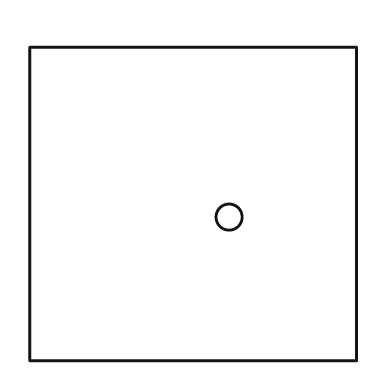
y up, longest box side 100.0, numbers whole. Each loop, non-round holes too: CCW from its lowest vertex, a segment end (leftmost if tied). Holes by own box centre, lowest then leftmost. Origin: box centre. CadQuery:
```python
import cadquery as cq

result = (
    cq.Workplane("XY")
    .moveTo(-50.0, -48.0)
    .lineTo(50.0, -48.0)
    .lineTo(50.0, 48.0)
    .lineTo(-50.0, 48.0)
    .close()
    .moveTo(11.0, -4.0)
    .circle(4.0)
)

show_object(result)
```